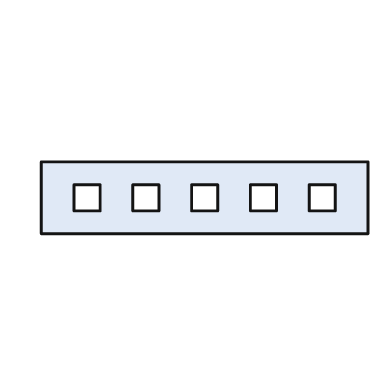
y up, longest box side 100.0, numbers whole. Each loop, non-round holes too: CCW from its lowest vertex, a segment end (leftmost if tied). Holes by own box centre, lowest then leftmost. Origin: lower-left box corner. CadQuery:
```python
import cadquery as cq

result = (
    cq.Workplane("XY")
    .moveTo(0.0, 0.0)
    .lineTo(100.0, 0.0)
    .lineTo(100.0, 22.0)
    .lineTo(0.0, 22.0)
    .close()
    .moveTo(10.0, 7.0)
    .lineTo(18.0, 7.0)
    .lineTo(18.0, 15.0)
    .lineTo(10.0, 15.0)
    .close()
    .moveTo(28.0, 7.0)
    .lineTo(36.0, 7.0)
    .lineTo(36.0, 15.0)
    .lineTo(28.0, 15.0)
    .close()
    .moveTo(46.0, 7.0)
    .lineTo(54.0, 7.0)
    .lineTo(54.0, 15.0)
    .lineTo(46.0, 15.0)
    .close()
    .moveTo(64.0, 7.0)
    .lineTo(72.0, 7.0)
    .lineTo(72.0, 15.0)
    .lineTo(64.0, 15.0)
    .close()
    .moveTo(82.0, 7.0)
    .lineTo(90.0, 7.0)
    .lineTo(90.0, 15.0)
    .lineTo(82.0, 15.0)
    .close()
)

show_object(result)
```